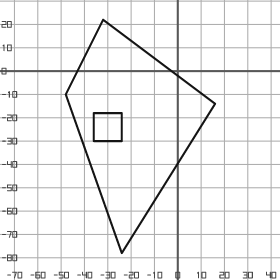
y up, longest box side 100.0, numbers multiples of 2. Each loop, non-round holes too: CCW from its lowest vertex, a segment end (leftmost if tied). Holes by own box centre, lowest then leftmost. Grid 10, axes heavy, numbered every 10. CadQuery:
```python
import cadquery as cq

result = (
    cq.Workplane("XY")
    .moveTo(-24.0, -78.0)
    .lineTo(16.0, -14.0)
    .lineTo(-32.0, 22.0)
    .lineTo(-48.0, -10.0)
    .close()
    .moveTo(-36.0, -30.0)
    .lineTo(-24.0, -30.0)
    .lineTo(-24.0, -18.0)
    .lineTo(-36.0, -18.0)
    .close()
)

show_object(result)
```